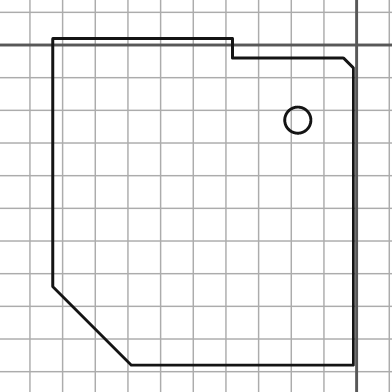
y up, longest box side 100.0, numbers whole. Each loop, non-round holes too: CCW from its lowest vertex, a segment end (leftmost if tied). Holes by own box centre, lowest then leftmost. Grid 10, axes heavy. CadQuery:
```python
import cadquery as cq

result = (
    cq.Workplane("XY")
    .moveTo(-69.0, -98.0)
    .lineTo(-1.0, -98.0)
    .lineTo(-1.0, -7.0)
    .lineTo(-4.0, -4.0)
    .lineTo(-38.0, -4.0)
    .lineTo(-38.0, 2.0)
    .lineTo(-93.0, 2.0)
    .lineTo(-93.0, -74.0)
    .close()
    .moveTo(-18.0, -23.0)
    .circle(4.0)
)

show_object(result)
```